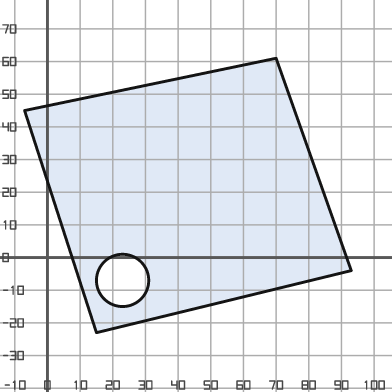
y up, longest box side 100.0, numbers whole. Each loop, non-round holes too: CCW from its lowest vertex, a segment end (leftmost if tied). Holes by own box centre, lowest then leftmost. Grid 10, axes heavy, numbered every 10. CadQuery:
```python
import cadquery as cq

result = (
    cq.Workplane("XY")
    .moveTo(15.0, -23.0)
    .lineTo(93.0, -4.0)
    .lineTo(70.0, 61.0)
    .lineTo(-7.0, 45.0)
    .close()
    .moveTo(23.0, -7.0)
    .circle(8.0)
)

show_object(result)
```